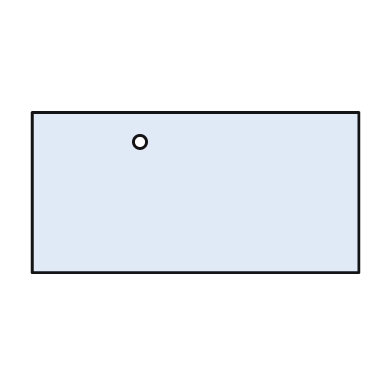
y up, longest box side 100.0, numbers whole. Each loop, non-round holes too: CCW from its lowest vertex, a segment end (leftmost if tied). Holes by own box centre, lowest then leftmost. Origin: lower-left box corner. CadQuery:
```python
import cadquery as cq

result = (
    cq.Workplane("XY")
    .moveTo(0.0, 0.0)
    .lineTo(100.0, 0.0)
    .lineTo(100.0, 49.0)
    .lineTo(0.0, 49.0)
    .close()
    .moveTo(33.0, 40.0)
    .circle(2.0)
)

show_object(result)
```